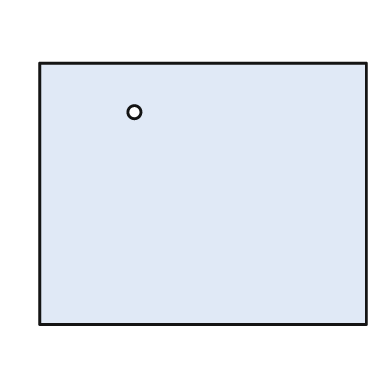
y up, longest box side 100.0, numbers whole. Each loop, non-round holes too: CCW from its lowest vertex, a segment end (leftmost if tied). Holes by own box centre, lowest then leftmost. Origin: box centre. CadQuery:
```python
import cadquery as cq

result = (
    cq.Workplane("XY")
    .moveTo(-50.0, -40.0)
    .lineTo(50.0, -40.0)
    .lineTo(50.0, 40.0)
    .lineTo(-50.0, 40.0)
    .close()
    .moveTo(-21.0, 25.0)
    .circle(2.0)
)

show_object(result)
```